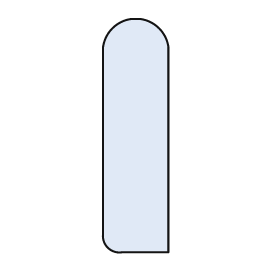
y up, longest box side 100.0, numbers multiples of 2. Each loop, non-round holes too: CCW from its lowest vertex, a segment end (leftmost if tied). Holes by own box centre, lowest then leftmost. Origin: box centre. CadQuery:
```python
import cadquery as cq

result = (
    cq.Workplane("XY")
    .moveTo(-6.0, -50.0)
    .lineTo(14.0, -50.0)
    .lineTo(14.0, 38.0)
    .threePointArc((10.0, 46.0), (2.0, 50.0))
    .lineTo(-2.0, 50.0)
    .threePointArc((-10.0, 46.0), (-14.0, 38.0))
    .lineTo(-14.0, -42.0)
    .threePointArc((-12.0, -48.0), (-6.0, -50.0))
    .close()
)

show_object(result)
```